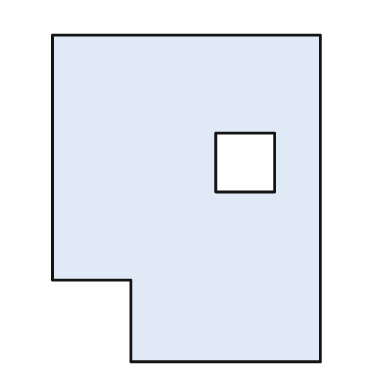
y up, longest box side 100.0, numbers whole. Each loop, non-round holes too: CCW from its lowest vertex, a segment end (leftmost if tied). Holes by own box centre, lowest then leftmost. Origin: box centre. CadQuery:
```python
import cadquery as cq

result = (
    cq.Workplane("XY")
    .moveTo(-17.0, -50.0)
    .lineTo(41.0, -50.0)
    .lineTo(41.0, 50.0)
    .lineTo(-41.0, 50.0)
    .lineTo(-41.0, -25.0)
    .lineTo(-17.0, -25.0)
    .close()
    .moveTo(9.0, 2.0)
    .lineTo(27.0, 2.0)
    .lineTo(27.0, 20.0)
    .lineTo(9.0, 20.0)
    .close()
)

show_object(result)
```